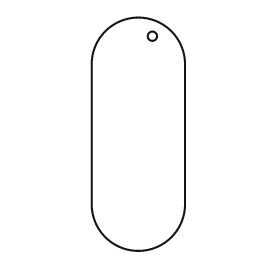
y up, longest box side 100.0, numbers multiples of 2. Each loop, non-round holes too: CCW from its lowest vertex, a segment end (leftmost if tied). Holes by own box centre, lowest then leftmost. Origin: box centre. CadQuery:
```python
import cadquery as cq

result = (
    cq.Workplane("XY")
    .moveTo(-20.0, -30.0)
    .threePointArc((0.0, -50.0), (20.0, -30.0))
    .lineTo(20.0, 30.0)
    .threePointArc((0.0, 50.0), (-20.0, 30.0))
    .close()
    .moveTo(6.0, 42.0)
    .circle(2.0)
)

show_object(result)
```